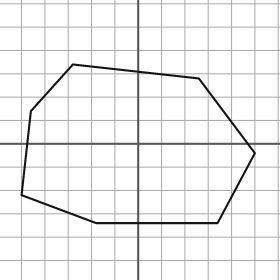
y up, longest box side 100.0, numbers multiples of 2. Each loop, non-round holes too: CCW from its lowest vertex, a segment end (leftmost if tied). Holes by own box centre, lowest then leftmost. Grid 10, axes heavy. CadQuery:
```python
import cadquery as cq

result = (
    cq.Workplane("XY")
    .moveTo(-18.0, -34.0)
    .lineTo(34.0, -34.0)
    .lineTo(50.0, -4.0)
    .lineTo(26.0, 28.0)
    .lineTo(-28.0, 34.0)
    .lineTo(-46.0, 14.0)
    .lineTo(-50.0, -22.0)
    .close()
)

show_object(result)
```